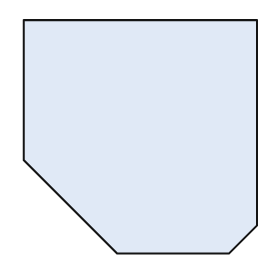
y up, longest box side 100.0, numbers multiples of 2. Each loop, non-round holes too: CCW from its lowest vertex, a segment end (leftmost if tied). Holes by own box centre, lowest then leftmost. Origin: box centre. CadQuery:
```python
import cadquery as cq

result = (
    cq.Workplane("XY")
    .moveTo(-10.0, -50.0)
    .lineTo(38.0, -50.0)
    .lineTo(50.0, -38.0)
    .lineTo(50.0, 50.0)
    .lineTo(-50.0, 50.0)
    .lineTo(-50.0, -10.0)
    .close()
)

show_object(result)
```